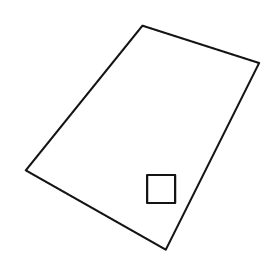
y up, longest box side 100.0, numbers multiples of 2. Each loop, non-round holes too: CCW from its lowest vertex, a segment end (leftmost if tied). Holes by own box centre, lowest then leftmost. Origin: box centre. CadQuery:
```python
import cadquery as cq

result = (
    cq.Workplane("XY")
    .moveTo(10.0, -48.0)
    .lineTo(50.0, 32.0)
    .lineTo(0.0, 48.0)
    .lineTo(-50.0, -14.0)
    .close()
    .moveTo(2.0, -28.0)
    .lineTo(14.0, -28.0)
    .lineTo(14.0, -16.0)
    .lineTo(2.0, -16.0)
    .close()
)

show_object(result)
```